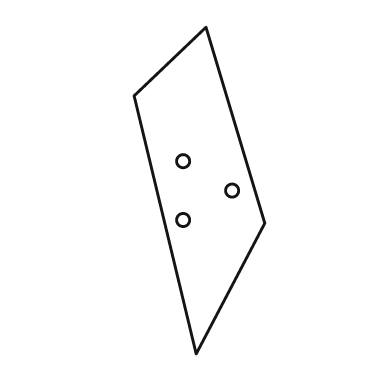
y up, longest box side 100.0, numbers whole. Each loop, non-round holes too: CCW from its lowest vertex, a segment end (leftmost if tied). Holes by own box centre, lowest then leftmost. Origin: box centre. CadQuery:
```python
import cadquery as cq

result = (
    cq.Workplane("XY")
    .moveTo(-1.0, -50.0)
    .lineTo(20.0, -10.0)
    .lineTo(2.0, 50.0)
    .lineTo(-20.0, 29.0)
    .close()
    .moveTo(-5.0, -9.0)
    .circle(2.0)
    .moveTo(10.0, 0.0)
    .circle(2.0)
    .moveTo(-5.0, 9.0)
    .circle(2.0)
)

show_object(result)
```